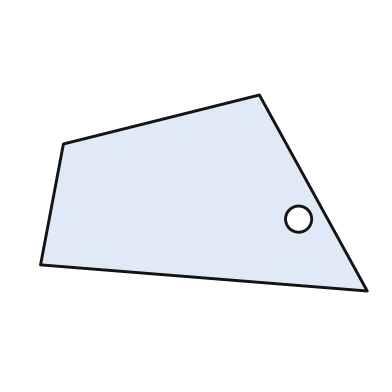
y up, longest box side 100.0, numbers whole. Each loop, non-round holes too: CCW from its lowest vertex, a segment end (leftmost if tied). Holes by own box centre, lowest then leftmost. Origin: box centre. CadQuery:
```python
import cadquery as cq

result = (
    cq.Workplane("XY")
    .moveTo(50.0, -30.0)
    .lineTo(17.0, 30.0)
    .lineTo(-43.0, 15.0)
    .lineTo(-50.0, -22.0)
    .close()
    .moveTo(29.0, -8.0)
    .circle(4.0)
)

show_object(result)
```